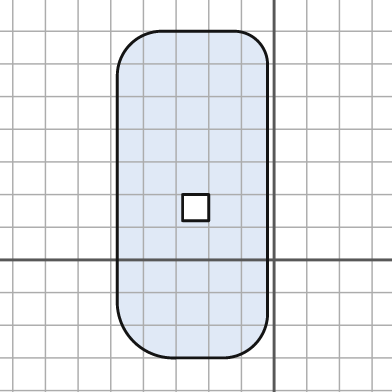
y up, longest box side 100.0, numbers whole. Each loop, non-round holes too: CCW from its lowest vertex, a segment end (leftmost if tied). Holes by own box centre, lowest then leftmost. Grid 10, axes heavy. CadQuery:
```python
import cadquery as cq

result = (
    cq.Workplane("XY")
    .moveTo(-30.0, -30.0)
    .lineTo(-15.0, -30.0)
    .threePointArc((-6.0, -26.0), (-2.0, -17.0))
    .lineTo(-2.0, 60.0)
    .threePointArc((-5.0, 67.0), (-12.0, 70.0))
    .lineTo(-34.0, 70.0)
    .threePointArc((-44.0, 66.0), (-48.0, 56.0))
    .lineTo(-48.0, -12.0)
    .threePointArc((-43.0, -25.0), (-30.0, -30.0))
    .close()
    .moveTo(-28.0, 12.0)
    .lineTo(-20.0, 12.0)
    .lineTo(-20.0, 20.0)
    .lineTo(-28.0, 20.0)
    .close()
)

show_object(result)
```